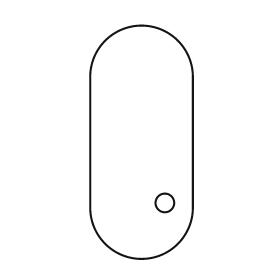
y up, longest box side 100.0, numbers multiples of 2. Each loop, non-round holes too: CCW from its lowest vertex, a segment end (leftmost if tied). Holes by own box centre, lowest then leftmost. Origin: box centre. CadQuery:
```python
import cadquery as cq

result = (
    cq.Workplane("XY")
    .moveTo(-22.0, -28.0)
    .threePointArc((0.0, -50.0), (22.0, -28.0))
    .lineTo(22.0, 28.0)
    .threePointArc((0.0, 50.0), (-22.0, 28.0))
    .close()
    .moveTo(10.0, -26.0)
    .circle(4.0)
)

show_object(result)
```